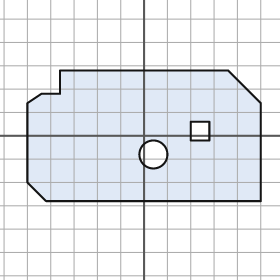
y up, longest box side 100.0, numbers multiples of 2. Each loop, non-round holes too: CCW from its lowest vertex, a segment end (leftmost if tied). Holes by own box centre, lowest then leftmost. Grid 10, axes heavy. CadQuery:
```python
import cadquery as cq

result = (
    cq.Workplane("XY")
    .moveTo(-42.0, -28.0)
    .lineTo(50.0, -28.0)
    .lineTo(50.0, 14.0)
    .lineTo(36.0, 28.0)
    .lineTo(-36.0, 28.0)
    .lineTo(-36.0, 18.0)
    .lineTo(-44.0, 18.0)
    .lineTo(-50.0, 14.0)
    .lineTo(-50.0, -20.0)
    .close()
    .moveTo(4.0, -8.0)
    .circle(6.0)
    .moveTo(20.0, -2.0)
    .lineTo(28.0, -2.0)
    .lineTo(28.0, 6.0)
    .lineTo(20.0, 6.0)
    .close()
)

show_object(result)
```